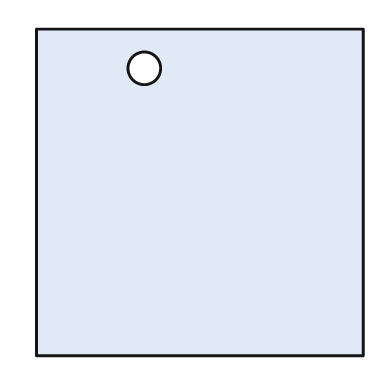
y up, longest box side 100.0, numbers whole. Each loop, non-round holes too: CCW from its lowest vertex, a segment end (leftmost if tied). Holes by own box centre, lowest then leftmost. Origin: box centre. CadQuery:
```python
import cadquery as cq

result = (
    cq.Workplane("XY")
    .moveTo(-50.0, -50.0)
    .lineTo(50.0, -50.0)
    .lineTo(50.0, 50.0)
    .lineTo(-50.0, 50.0)
    .close()
    .moveTo(-17.0, 38.0)
    .circle(5.0)
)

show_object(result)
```